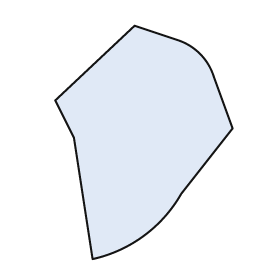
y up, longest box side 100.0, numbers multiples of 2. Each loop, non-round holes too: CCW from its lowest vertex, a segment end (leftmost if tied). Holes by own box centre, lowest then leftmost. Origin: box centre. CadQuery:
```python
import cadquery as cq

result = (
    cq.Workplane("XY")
    .moveTo(-22.0, -50.0)
    .threePointArc((0.0, -40.0), (16.0, -22.0))
    .lineTo(38.0, 6.0)
    .lineTo(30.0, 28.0)
    .threePointArc((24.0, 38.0), (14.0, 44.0))
    .lineTo(-4.0, 50.0)
    .lineTo(-38.0, 18.0)
    .lineTo(-30.0, 2.0)
    .close()
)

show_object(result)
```